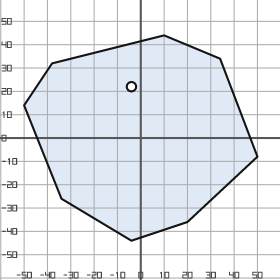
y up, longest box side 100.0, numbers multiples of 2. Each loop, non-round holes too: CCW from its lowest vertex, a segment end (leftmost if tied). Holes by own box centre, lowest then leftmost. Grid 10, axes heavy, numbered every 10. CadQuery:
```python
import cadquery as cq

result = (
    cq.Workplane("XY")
    .moveTo(-4.0, -44.0)
    .lineTo(20.0, -36.0)
    .lineTo(50.0, -8.0)
    .lineTo(34.0, 34.0)
    .lineTo(10.0, 44.0)
    .lineTo(-38.0, 32.0)
    .lineTo(-50.0, 14.0)
    .lineTo(-34.0, -26.0)
    .close()
    .moveTo(-4.0, 22.0)
    .circle(2.0)
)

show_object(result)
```